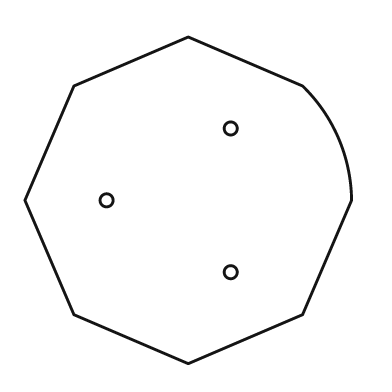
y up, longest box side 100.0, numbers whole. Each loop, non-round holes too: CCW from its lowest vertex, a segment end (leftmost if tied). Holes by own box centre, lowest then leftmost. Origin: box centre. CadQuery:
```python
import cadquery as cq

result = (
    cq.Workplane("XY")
    .moveTo(0.0, -50.0)
    .lineTo(35.0, -35.0)
    .lineTo(50.0, 0.0)
    .threePointArc((46.0, 19.0), (35.0, 35.0))
    .lineTo(0.0, 50.0)
    .lineTo(-35.0, 35.0)
    .lineTo(-50.0, 0.0)
    .lineTo(-35.0, -35.0)
    .close()
    .moveTo(13.0, -22.0)
    .circle(2.0)
    .moveTo(-25.0, 0.0)
    .circle(2.0)
    .moveTo(13.0, 22.0)
    .circle(2.0)
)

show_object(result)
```